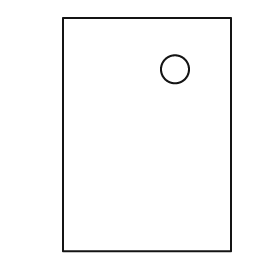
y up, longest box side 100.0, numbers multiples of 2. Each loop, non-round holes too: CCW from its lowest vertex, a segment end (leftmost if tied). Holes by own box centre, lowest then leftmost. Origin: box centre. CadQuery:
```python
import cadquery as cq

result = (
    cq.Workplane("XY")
    .moveTo(-36.0, -50.0)
    .lineTo(36.0, -50.0)
    .lineTo(36.0, 50.0)
    .lineTo(-36.0, 50.0)
    .close()
    .moveTo(12.0, 28.0)
    .circle(6.0)
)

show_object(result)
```